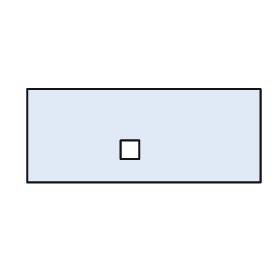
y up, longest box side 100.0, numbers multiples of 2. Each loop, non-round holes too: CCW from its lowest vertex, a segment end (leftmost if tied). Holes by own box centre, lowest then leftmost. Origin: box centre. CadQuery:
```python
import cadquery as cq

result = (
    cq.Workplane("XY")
    .moveTo(-50.0, -20.0)
    .lineTo(50.0, -20.0)
    .lineTo(50.0, 20.0)
    .lineTo(-50.0, 20.0)
    .close()
    .moveTo(-10.0, -10.0)
    .lineTo(-2.0, -10.0)
    .lineTo(-2.0, -2.0)
    .lineTo(-10.0, -2.0)
    .close()
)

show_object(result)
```